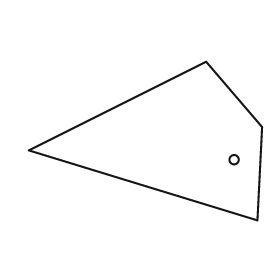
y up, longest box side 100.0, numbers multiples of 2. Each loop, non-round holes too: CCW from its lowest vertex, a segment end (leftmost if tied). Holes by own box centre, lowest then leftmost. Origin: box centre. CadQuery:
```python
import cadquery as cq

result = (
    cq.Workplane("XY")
    .moveTo(48.0, -34.0)
    .lineTo(50.0, 6.0)
    .lineTo(26.0, 34.0)
    .lineTo(-50.0, -4.0)
    .close()
    .moveTo(38.0, -8.0)
    .circle(2.0)
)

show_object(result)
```